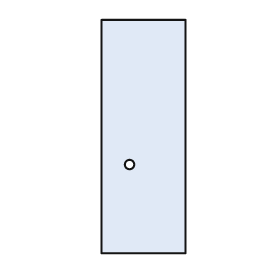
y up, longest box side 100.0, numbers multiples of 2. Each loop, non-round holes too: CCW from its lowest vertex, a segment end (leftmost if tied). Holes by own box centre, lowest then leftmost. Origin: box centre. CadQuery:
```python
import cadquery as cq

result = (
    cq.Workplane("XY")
    .moveTo(-18.0, -50.0)
    .lineTo(18.0, -50.0)
    .lineTo(18.0, 50.0)
    .lineTo(-18.0, 50.0)
    .close()
    .moveTo(-6.0, -12.0)
    .circle(2.0)
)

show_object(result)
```